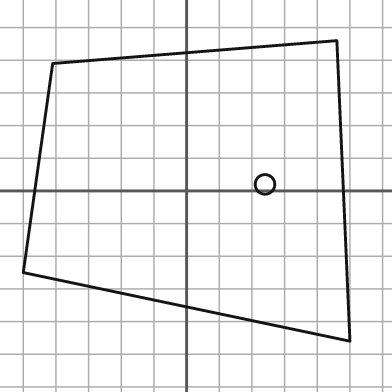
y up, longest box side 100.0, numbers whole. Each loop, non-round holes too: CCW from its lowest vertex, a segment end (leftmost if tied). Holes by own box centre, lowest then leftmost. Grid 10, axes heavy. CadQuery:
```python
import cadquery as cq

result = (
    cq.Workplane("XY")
    .moveTo(50.0, -46.0)
    .lineTo(46.0, 46.0)
    .lineTo(-41.0, 39.0)
    .lineTo(-50.0, -25.0)
    .close()
    .moveTo(24.0, 2.0)
    .circle(3.0)
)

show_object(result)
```